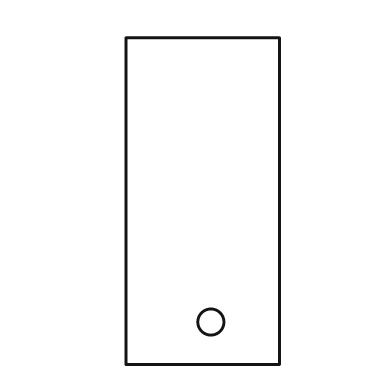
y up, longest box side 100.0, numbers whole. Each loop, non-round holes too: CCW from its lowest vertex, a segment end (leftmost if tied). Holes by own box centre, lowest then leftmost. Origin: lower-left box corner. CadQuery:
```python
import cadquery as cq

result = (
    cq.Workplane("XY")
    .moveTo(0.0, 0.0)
    .lineTo(47.0, 0.0)
    .lineTo(47.0, 100.0)
    .lineTo(0.0, 100.0)
    .close()
    .moveTo(26.0, 13.0)
    .circle(4.0)
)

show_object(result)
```